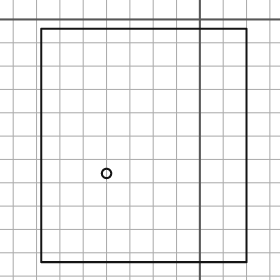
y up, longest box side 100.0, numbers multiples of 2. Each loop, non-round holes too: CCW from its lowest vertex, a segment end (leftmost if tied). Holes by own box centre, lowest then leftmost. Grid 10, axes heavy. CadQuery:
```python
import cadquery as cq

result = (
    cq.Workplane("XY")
    .moveTo(-68.0, -104.0)
    .lineTo(20.0, -104.0)
    .lineTo(20.0, -4.0)
    .lineTo(-68.0, -4.0)
    .close()
    .moveTo(-40.0, -66.0)
    .circle(2.0)
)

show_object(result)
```